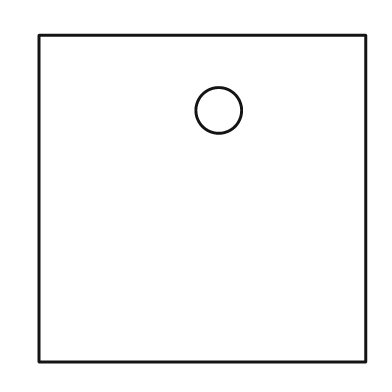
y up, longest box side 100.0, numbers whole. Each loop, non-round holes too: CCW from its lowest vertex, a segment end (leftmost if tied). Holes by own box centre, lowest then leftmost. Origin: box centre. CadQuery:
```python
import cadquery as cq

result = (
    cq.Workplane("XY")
    .moveTo(-50.0, -50.0)
    .lineTo(50.0, -50.0)
    .lineTo(50.0, 50.0)
    .lineTo(-50.0, 50.0)
    .close()
    .moveTo(5.0, 27.0)
    .circle(7.0)
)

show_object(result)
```